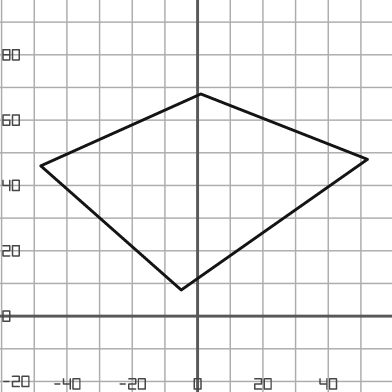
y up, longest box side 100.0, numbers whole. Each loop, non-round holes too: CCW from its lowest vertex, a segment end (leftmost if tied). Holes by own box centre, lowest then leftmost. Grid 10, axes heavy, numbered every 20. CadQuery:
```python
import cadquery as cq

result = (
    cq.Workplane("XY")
    .moveTo(-5.0, 8.0)
    .lineTo(52.0, 48.0)
    .lineTo(1.0, 68.0)
    .lineTo(-48.0, 46.0)
    .close()
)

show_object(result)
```